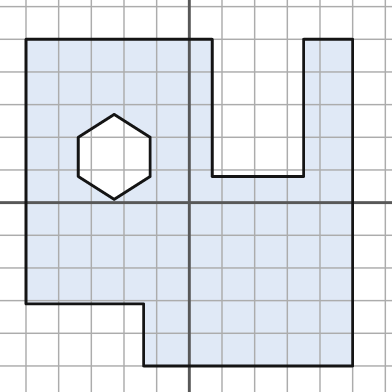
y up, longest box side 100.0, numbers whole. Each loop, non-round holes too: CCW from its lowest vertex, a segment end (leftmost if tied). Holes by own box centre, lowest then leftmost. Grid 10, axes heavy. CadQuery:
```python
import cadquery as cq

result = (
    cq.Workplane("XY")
    .moveTo(-14.0, -50.0)
    .lineTo(50.0, -50.0)
    .lineTo(50.0, 50.0)
    .lineTo(35.0, 50.0)
    .lineTo(35.0, 8.0)
    .lineTo(7.0, 8.0)
    .lineTo(7.0, 50.0)
    .lineTo(-50.0, 50.0)
    .lineTo(-50.0, -31.0)
    .lineTo(-14.0, -31.0)
    .close()
    .moveTo(-23.0, 1.0)
    .lineTo(-12.0, 8.0)
    .lineTo(-12.0, 20.0)
    .lineTo(-23.0, 27.0)
    .lineTo(-34.0, 20.0)
    .lineTo(-34.0, 8.0)
    .close()
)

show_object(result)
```